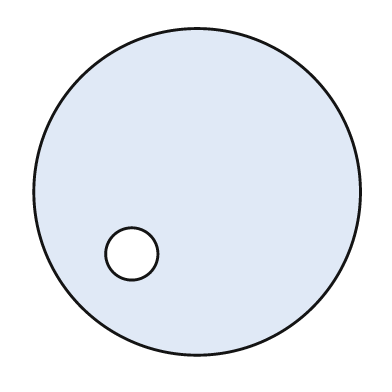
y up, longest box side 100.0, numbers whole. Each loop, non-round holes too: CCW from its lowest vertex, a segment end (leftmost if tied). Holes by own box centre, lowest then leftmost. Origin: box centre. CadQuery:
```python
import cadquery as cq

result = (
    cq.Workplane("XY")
    .moveTo(0.0, 0.0)
    .circle(50.0)
    .moveTo(-20.0, -19.0)
    .circle(8.0)
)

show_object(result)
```